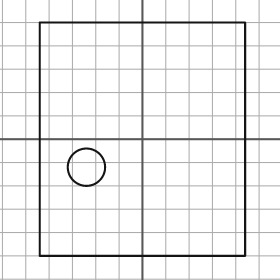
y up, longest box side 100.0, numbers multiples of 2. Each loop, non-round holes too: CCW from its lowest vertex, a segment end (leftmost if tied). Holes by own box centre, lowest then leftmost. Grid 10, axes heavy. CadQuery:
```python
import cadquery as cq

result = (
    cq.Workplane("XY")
    .moveTo(-44.0, -50.0)
    .lineTo(44.0, -50.0)
    .lineTo(44.0, 50.0)
    .lineTo(-44.0, 50.0)
    .close()
    .moveTo(-24.0, -12.0)
    .circle(8.0)
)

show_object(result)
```